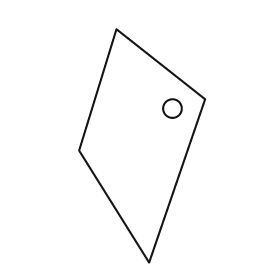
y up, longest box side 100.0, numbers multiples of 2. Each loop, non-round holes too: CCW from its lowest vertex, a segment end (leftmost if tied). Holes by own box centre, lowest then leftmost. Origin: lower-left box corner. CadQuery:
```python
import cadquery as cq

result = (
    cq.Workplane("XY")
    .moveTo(30.0, 0.0)
    .lineTo(54.0, 70.0)
    .lineTo(16.0, 100.0)
    .lineTo(0.0, 48.0)
    .close()
    .moveTo(40.0, 66.0)
    .circle(4.0)
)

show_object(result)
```